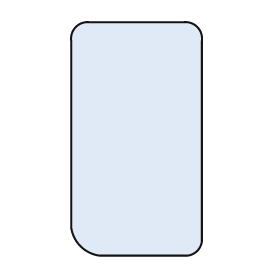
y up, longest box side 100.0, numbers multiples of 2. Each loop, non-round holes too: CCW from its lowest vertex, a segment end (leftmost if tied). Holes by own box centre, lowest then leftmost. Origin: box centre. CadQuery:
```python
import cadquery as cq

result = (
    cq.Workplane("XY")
    .moveTo(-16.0, -50.0)
    .lineTo(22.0, -50.0)
    .threePointArc((26.0, -48.0), (28.0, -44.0))
    .lineTo(28.0, 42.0)
    .threePointArc((26.0, 48.0), (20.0, 50.0))
    .lineTo(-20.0, 50.0)
    .threePointArc((-26.0, 48.0), (-28.0, 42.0))
    .lineTo(-28.0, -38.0)
    .threePointArc((-24.0, -46.0), (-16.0, -50.0))
    .close()
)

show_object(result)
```